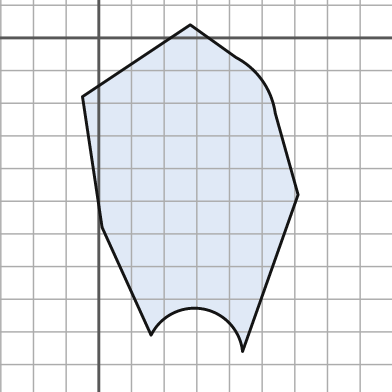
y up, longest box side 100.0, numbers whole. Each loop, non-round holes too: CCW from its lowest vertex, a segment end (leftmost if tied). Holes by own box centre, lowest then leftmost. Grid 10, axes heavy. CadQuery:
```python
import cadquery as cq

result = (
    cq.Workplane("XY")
    .moveTo(44.0, -96.0)
    .lineTo(61.0, -48.0)
    .lineTo(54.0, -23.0)
    .threePointArc((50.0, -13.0), (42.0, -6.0))
    .lineTo(28.0, 4.0)
    .lineTo(-5.0, -18.0)
    .lineTo(1.0, -58.0)
    .lineTo(16.0, -91.0)
    .threePointArc((32.0, -83.0), (44.0, -96.0))
    .close()
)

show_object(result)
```